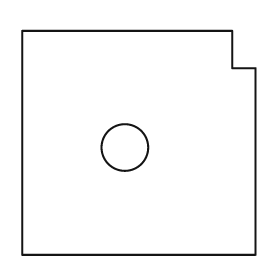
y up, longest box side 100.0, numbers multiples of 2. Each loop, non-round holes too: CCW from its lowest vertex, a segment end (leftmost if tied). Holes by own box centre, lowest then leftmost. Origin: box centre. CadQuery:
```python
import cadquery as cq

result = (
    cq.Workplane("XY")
    .moveTo(-50.0, -48.0)
    .lineTo(50.0, -48.0)
    .lineTo(50.0, 32.0)
    .lineTo(40.0, 32.0)
    .lineTo(40.0, 48.0)
    .lineTo(-50.0, 48.0)
    .close()
    .moveTo(-6.0, -2.0)
    .circle(10.0)
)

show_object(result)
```